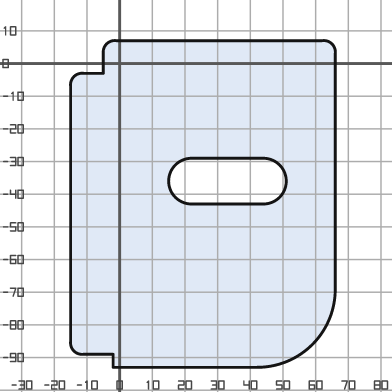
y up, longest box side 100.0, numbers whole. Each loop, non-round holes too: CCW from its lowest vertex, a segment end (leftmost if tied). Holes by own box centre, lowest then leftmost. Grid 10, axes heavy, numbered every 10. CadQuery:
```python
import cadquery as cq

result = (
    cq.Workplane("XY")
    .moveTo(-2.0, -93.0)
    .lineTo(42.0, -93.0)
    .threePointArc((59.0, -86.0), (66.0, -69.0))
    .lineTo(66.0, 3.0)
    .threePointArc((65.0, 6.0), (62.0, 7.0))
    .lineTo(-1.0, 7.0)
    .threePointArc((-4.0, 6.0), (-5.0, 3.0))
    .lineTo(-5.0, -3.0)
    .lineTo(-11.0, -3.0)
    .threePointArc((-14.0, -4.0), (-15.0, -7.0))
    .lineTo(-15.0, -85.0)
    .threePointArc((-14.0, -88.0), (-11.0, -89.0))
    .lineTo(-2.0, -89.0)
    .close()
    .moveTo(22.0, -43.0)
    .lineTo(44.0, -43.0)
    .threePointArc((51.0, -36.0), (44.0, -29.0))
    .lineTo(22.0, -29.0)
    .threePointArc((15.0, -36.0), (22.0, -43.0))
    .close()
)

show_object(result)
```